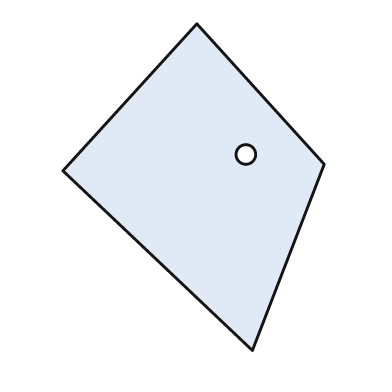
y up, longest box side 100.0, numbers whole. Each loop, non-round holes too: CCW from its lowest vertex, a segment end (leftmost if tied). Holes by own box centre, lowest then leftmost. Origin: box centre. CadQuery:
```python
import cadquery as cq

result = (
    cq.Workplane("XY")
    .moveTo(18.0, -50.0)
    .lineTo(40.0, 7.0)
    .lineTo(1.0, 50.0)
    .lineTo(-40.0, 5.0)
    .close()
    .moveTo(16.0, 10.0)
    .circle(3.0)
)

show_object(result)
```